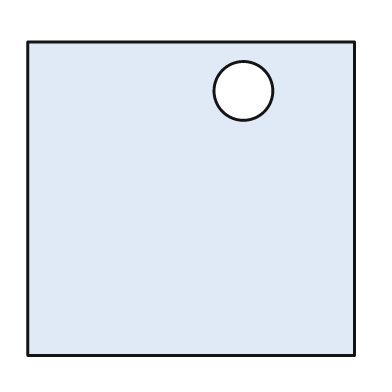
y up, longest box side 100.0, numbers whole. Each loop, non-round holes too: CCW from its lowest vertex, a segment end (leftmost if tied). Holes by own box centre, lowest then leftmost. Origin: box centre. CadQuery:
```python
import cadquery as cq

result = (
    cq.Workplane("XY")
    .moveTo(-50.0, -48.0)
    .lineTo(50.0, -48.0)
    .lineTo(50.0, 48.0)
    .lineTo(-50.0, 48.0)
    .close()
    .moveTo(16.0, 33.0)
    .circle(9.0)
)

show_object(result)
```